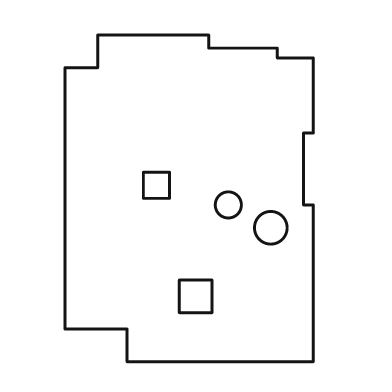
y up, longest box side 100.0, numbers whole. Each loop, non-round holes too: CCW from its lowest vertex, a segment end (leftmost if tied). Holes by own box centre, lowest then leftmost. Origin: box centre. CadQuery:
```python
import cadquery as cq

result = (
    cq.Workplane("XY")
    .moveTo(-19.0, -50.0)
    .lineTo(38.0, -50.0)
    .lineTo(38.0, -2.0)
    .lineTo(35.0, -2.0)
    .lineTo(35.0, 20.0)
    .lineTo(38.0, 20.0)
    .lineTo(38.0, 43.0)
    .lineTo(27.0, 43.0)
    .lineTo(27.0, 46.0)
    .lineTo(6.0, 46.0)
    .lineTo(6.0, 50.0)
    .lineTo(-28.0, 50.0)
    .lineTo(-28.0, 40.0)
    .lineTo(-38.0, 40.0)
    .lineTo(-38.0, -40.0)
    .lineTo(-19.0, -40.0)
    .close()
    .moveTo(-3.0, -35.0)
    .lineTo(7.0, -35.0)
    .lineTo(7.0, -25.0)
    .lineTo(-3.0, -25.0)
    .close()
    .moveTo(25.0, -9.0)
    .circle(5.0)
    .moveTo(12.0, -2.0)
    .circle(4.0)
    .moveTo(-14.0, 0.0)
    .lineTo(-6.0, 0.0)
    .lineTo(-6.0, 8.0)
    .lineTo(-14.0, 8.0)
    .close()
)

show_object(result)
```